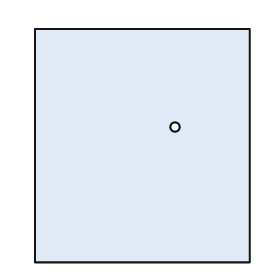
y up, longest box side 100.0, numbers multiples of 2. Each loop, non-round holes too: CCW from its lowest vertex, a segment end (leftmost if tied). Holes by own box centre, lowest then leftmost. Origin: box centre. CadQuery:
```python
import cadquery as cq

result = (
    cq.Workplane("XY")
    .moveTo(-46.0, -50.0)
    .lineTo(46.0, -50.0)
    .lineTo(46.0, 50.0)
    .lineTo(-46.0, 50.0)
    .close()
    .moveTo(14.0, 8.0)
    .circle(2.0)
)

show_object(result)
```